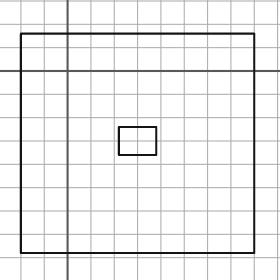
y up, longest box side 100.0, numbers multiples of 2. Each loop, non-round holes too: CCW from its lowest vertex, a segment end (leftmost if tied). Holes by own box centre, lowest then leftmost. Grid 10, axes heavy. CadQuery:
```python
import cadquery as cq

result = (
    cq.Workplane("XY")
    .moveTo(-20.0, -78.0)
    .lineTo(80.0, -78.0)
    .lineTo(80.0, 16.0)
    .lineTo(-20.0, 16.0)
    .close()
    .moveTo(22.0, -36.0)
    .lineTo(38.0, -36.0)
    .lineTo(38.0, -24.0)
    .lineTo(22.0, -24.0)
    .close()
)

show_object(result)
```